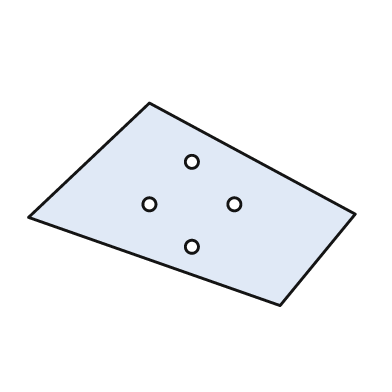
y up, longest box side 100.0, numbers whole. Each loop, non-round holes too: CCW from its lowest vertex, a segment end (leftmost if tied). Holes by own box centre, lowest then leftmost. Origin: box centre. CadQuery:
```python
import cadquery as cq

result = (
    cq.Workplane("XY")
    .moveTo(27.0, -31.0)
    .lineTo(50.0, -3.0)
    .lineTo(-13.0, 31.0)
    .lineTo(-50.0, -4.0)
    .close()
    .moveTo(0.0, -13.0)
    .circle(2.0)
    .moveTo(-13.0, 0.0)
    .circle(2.0)
    .moveTo(13.0, 0.0)
    .circle(2.0)
    .moveTo(0.0, 13.0)
    .circle(2.0)
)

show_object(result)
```